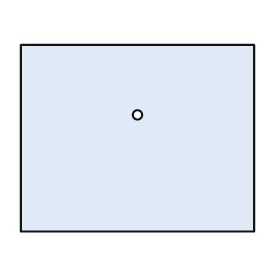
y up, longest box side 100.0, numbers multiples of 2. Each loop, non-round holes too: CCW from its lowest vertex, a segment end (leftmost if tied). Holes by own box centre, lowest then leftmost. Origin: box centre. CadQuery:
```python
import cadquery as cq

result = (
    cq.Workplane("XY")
    .moveTo(-50.0, -40.0)
    .lineTo(50.0, -40.0)
    .lineTo(50.0, 40.0)
    .lineTo(-50.0, 40.0)
    .close()
    .moveTo(0.0, 10.0)
    .circle(2.0)
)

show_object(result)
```